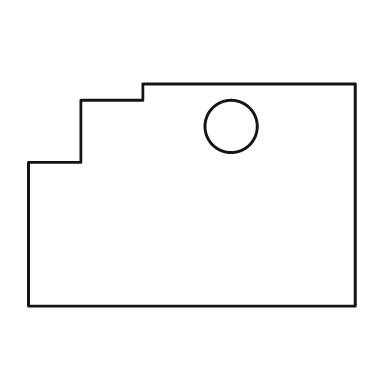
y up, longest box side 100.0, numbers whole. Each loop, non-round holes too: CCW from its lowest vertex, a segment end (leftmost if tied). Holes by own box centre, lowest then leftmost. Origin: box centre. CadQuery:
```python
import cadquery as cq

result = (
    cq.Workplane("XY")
    .moveTo(-50.0, -34.0)
    .lineTo(50.0, -34.0)
    .lineTo(50.0, 34.0)
    .lineTo(-15.0, 34.0)
    .lineTo(-15.0, 29.0)
    .lineTo(-34.0, 29.0)
    .lineTo(-34.0, 10.0)
    .lineTo(-50.0, 10.0)
    .close()
    .moveTo(12.0, 21.0)
    .circle(8.0)
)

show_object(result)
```